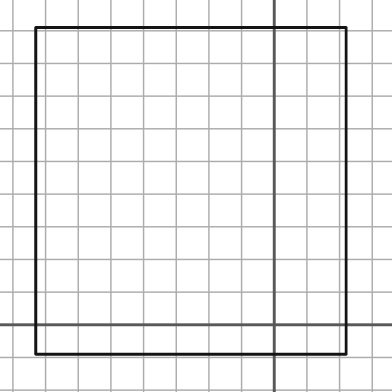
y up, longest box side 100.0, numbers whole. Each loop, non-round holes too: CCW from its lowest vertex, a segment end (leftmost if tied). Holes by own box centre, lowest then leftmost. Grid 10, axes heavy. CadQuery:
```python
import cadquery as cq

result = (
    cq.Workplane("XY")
    .moveTo(-73.0, -9.0)
    .lineTo(22.0, -9.0)
    .lineTo(22.0, 91.0)
    .lineTo(-73.0, 91.0)
    .close()
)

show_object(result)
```